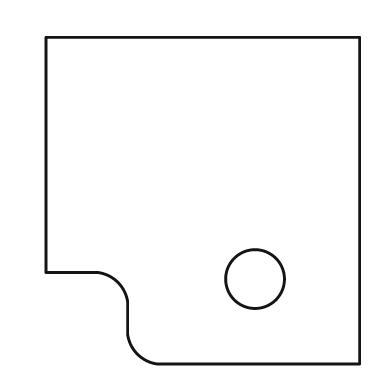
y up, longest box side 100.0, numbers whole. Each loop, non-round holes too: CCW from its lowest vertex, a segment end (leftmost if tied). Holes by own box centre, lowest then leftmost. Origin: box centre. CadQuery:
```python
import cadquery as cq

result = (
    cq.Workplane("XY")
    .moveTo(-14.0, -50.0)
    .lineTo(48.0, -50.0)
    .lineTo(48.0, 50.0)
    .lineTo(-48.0, 50.0)
    .lineTo(-48.0, -22.0)
    .lineTo(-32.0, -22.0)
    .threePointArc((-26.0, -25.0), (-23.0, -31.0))
    .lineTo(-23.0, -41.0)
    .threePointArc((-20.0, -47.0), (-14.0, -50.0))
    .close()
    .moveTo(16.0, -24.0)
    .circle(9.0)
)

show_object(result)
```